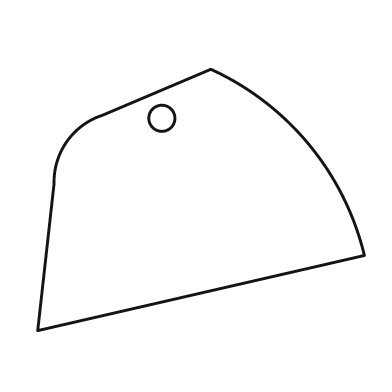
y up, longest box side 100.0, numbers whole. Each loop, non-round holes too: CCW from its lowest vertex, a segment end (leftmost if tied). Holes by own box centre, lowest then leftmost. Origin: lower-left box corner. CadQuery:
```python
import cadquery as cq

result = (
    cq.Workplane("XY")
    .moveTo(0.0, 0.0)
    .lineTo(100.0, 23.0)
    .threePointArc((83.0, 57.0), (53.0, 80.0))
    .lineTo(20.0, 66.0)
    .threePointArc((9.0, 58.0), (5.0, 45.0))
    .close()
    .moveTo(38.0, 65.0)
    .circle(4.0)
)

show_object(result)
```